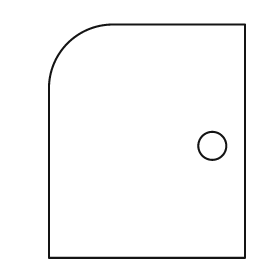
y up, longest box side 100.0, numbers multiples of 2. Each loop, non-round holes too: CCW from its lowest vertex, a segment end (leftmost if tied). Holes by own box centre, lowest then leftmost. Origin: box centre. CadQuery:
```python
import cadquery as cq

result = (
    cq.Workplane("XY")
    .moveTo(-42.0, -50.0)
    .lineTo(42.0, -50.0)
    .lineTo(42.0, 50.0)
    .lineTo(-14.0, 50.0)
    .threePointArc((-34.0, 42.0), (-42.0, 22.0))
    .close()
    .moveTo(28.0, -2.0)
    .circle(6.0)
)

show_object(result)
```